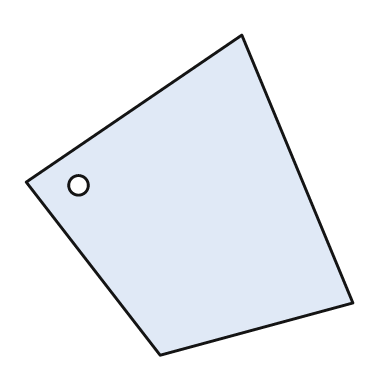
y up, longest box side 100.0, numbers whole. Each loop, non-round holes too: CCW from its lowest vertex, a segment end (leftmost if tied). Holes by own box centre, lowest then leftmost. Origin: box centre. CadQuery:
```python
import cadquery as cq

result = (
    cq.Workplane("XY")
    .moveTo(-9.0, -49.0)
    .lineTo(50.0, -33.0)
    .lineTo(16.0, 49.0)
    .lineTo(-50.0, 4.0)
    .close()
    .moveTo(-34.0, 3.0)
    .circle(3.0)
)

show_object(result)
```